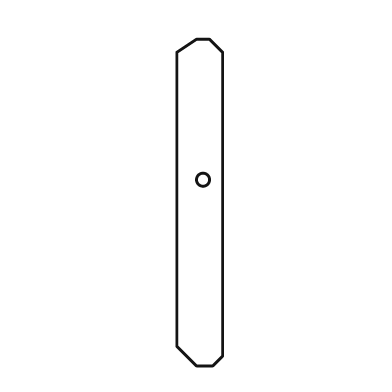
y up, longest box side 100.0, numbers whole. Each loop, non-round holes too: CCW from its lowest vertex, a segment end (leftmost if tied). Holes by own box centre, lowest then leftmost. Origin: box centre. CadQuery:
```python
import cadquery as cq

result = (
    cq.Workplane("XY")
    .moveTo(-1.0, -50.0)
    .lineTo(4.0, -50.0)
    .lineTo(7.0, -47.0)
    .lineTo(7.0, 46.0)
    .lineTo(3.0, 50.0)
    .lineTo(-1.0, 50.0)
    .lineTo(-7.0, 46.0)
    .lineTo(-7.0, -44.0)
    .close()
    .moveTo(1.0, 7.0)
    .circle(2.0)
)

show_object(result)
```